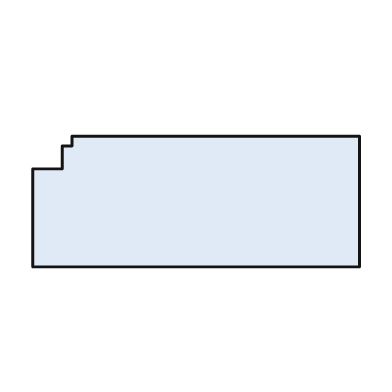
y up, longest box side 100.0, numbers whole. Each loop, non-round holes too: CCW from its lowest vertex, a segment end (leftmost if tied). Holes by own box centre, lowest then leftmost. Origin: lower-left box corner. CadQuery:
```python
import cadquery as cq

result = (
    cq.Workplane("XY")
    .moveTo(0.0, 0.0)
    .lineTo(100.0, 0.0)
    .lineTo(100.0, 40.0)
    .lineTo(12.0, 40.0)
    .lineTo(12.0, 37.0)
    .lineTo(9.0, 37.0)
    .lineTo(9.0, 30.0)
    .lineTo(0.0, 30.0)
    .close()
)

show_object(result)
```